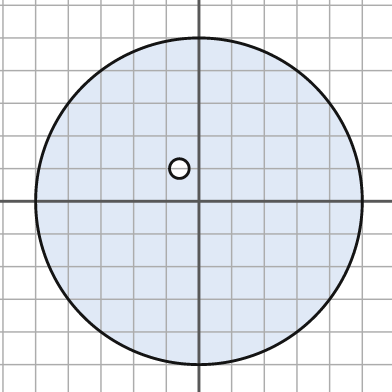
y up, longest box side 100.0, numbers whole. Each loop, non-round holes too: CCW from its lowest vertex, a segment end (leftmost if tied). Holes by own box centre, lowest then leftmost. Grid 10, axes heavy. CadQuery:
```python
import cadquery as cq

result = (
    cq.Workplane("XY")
    .moveTo(0.0, 0.0)
    .circle(50.0)
    .moveTo(-6.0, 10.0)
    .circle(3.0)
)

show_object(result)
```